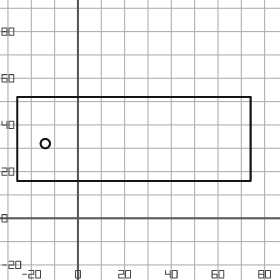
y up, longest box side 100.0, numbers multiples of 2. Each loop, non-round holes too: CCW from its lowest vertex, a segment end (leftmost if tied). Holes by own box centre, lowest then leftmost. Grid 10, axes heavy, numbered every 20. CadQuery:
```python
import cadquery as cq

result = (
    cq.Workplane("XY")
    .moveTo(-26.0, 16.0)
    .lineTo(74.0, 16.0)
    .lineTo(74.0, 52.0)
    .lineTo(-26.0, 52.0)
    .close()
    .moveTo(-14.0, 32.0)
    .circle(2.0)
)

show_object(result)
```